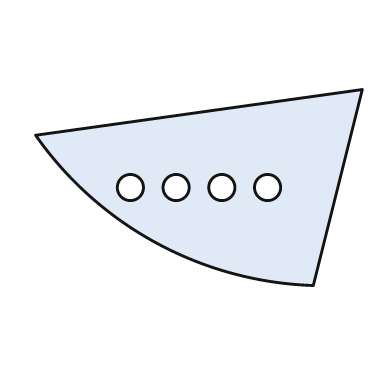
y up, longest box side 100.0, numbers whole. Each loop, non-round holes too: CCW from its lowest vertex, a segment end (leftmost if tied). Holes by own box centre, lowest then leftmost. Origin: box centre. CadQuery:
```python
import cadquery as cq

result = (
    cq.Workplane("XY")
    .moveTo(35.0, -30.0)
    .lineTo(50.0, 30.0)
    .lineTo(-50.0, 16.0)
    .threePointArc((-13.0, -17.0), (35.0, -30.0))
    .close()
    .moveTo(-21.0, 0.0)
    .circle(4.0)
    .moveTo(-7.0, 0.0)
    .circle(4.0)
    .moveTo(7.0, 0.0)
    .circle(4.0)
    .moveTo(21.0, 0.0)
    .circle(4.0)
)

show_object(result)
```